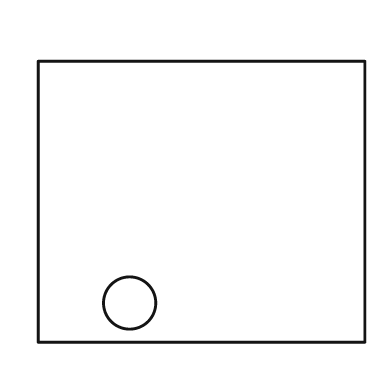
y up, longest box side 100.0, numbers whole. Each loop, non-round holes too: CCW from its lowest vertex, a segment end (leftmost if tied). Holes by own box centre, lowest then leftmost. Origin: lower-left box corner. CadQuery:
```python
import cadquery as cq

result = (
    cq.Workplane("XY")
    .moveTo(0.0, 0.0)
    .lineTo(100.0, 0.0)
    .lineTo(100.0, 86.0)
    .lineTo(0.0, 86.0)
    .close()
    .moveTo(28.0, 12.0)
    .circle(8.0)
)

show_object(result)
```